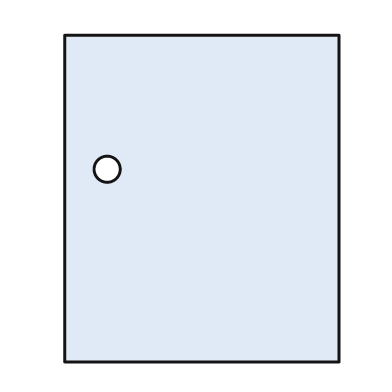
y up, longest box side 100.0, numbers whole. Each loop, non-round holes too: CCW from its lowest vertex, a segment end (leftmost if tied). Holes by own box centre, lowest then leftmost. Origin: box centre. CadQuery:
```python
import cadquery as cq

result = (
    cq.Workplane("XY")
    .moveTo(-42.0, -50.0)
    .lineTo(42.0, -50.0)
    .lineTo(42.0, 50.0)
    .lineTo(-42.0, 50.0)
    .close()
    .moveTo(-29.0, 9.0)
    .circle(4.0)
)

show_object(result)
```